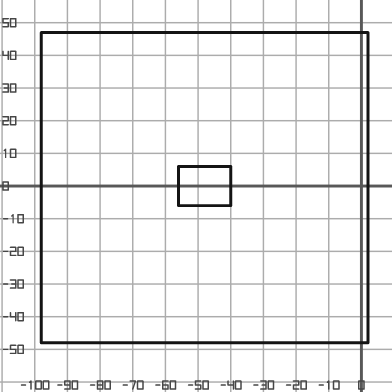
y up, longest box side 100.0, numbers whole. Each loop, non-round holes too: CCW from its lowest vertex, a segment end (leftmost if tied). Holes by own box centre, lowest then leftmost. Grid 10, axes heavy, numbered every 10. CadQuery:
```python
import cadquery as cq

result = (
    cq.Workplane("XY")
    .moveTo(-98.0, -48.0)
    .lineTo(2.0, -48.0)
    .lineTo(2.0, 47.0)
    .lineTo(-98.0, 47.0)
    .close()
    .moveTo(-56.0, -6.0)
    .lineTo(-40.0, -6.0)
    .lineTo(-40.0, 6.0)
    .lineTo(-56.0, 6.0)
    .close()
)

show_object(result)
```